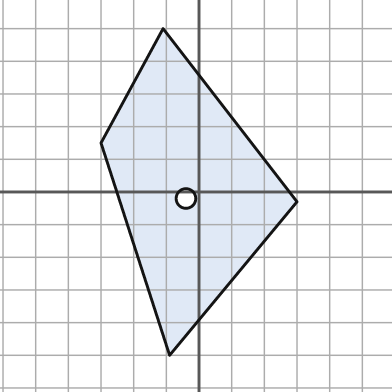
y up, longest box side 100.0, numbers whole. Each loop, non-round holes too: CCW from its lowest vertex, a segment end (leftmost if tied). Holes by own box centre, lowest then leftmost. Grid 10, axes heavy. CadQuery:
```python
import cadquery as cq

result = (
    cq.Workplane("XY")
    .moveTo(-9.0, -50.0)
    .lineTo(30.0, -3.0)
    .lineTo(-11.0, 50.0)
    .lineTo(-30.0, 15.0)
    .close()
    .moveTo(-4.0, -2.0)
    .circle(3.0)
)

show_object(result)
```